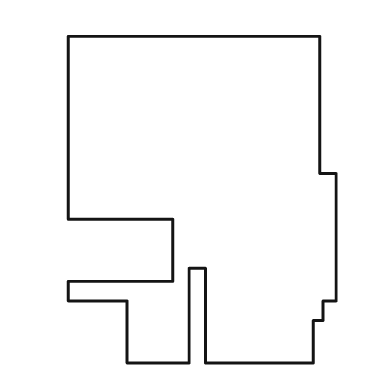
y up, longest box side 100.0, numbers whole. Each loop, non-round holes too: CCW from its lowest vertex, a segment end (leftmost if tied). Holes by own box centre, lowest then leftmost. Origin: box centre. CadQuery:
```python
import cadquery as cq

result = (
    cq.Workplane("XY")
    .moveTo(-23.0, -50.0)
    .lineTo(-4.0, -50.0)
    .lineTo(-4.0, -21.0)
    .lineTo(1.0, -21.0)
    .lineTo(1.0, -50.0)
    .lineTo(34.0, -50.0)
    .lineTo(34.0, -37.0)
    .lineTo(37.0, -37.0)
    .lineTo(37.0, -31.0)
    .lineTo(41.0, -31.0)
    .lineTo(41.0, 8.0)
    .lineTo(36.0, 8.0)
    .lineTo(36.0, 50.0)
    .lineTo(-41.0, 50.0)
    .lineTo(-41.0, -6.0)
    .lineTo(-9.0, -6.0)
    .lineTo(-9.0, -25.0)
    .lineTo(-41.0, -25.0)
    .lineTo(-41.0, -31.0)
    .lineTo(-23.0, -31.0)
    .close()
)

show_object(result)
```